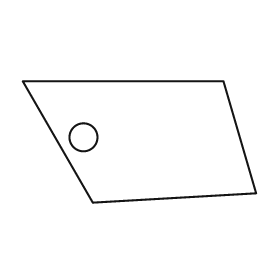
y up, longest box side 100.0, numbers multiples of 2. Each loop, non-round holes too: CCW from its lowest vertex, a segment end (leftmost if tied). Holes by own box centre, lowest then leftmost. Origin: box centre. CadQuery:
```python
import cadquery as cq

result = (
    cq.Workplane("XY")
    .moveTo(-20.0, -26.0)
    .lineTo(50.0, -22.0)
    .lineTo(36.0, 26.0)
    .lineTo(-50.0, 26.0)
    .close()
    .moveTo(-24.0, 2.0)
    .circle(6.0)
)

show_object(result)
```